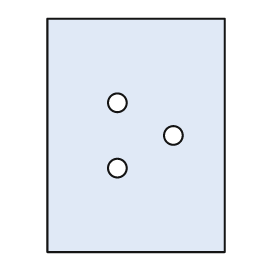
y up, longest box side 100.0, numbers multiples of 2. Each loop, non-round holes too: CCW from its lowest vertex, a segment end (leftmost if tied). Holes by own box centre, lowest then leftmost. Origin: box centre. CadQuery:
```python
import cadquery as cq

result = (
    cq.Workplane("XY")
    .moveTo(-38.0, -50.0)
    .lineTo(38.0, -50.0)
    .lineTo(38.0, 50.0)
    .lineTo(-38.0, 50.0)
    .close()
    .moveTo(-8.0, -14.0)
    .circle(4.0)
    .moveTo(16.0, 0.0)
    .circle(4.0)
    .moveTo(-8.0, 14.0)
    .circle(4.0)
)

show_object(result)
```